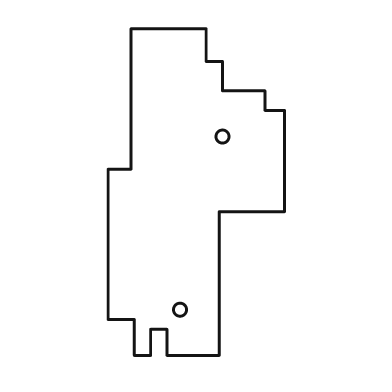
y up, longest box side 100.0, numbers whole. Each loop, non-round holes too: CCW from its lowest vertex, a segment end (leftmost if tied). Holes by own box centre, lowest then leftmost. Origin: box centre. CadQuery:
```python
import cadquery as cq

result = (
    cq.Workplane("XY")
    .moveTo(-19.0, -50.0)
    .lineTo(-14.0, -50.0)
    .lineTo(-14.0, -42.0)
    .lineTo(-9.0, -42.0)
    .lineTo(-9.0, -50.0)
    .lineTo(7.0, -50.0)
    .lineTo(7.0, -6.0)
    .lineTo(27.0, -6.0)
    .lineTo(27.0, 25.0)
    .lineTo(21.0, 25.0)
    .lineTo(21.0, 31.0)
    .lineTo(8.0, 31.0)
    .lineTo(8.0, 40.0)
    .lineTo(3.0, 40.0)
    .lineTo(3.0, 50.0)
    .lineTo(-20.0, 50.0)
    .lineTo(-20.0, 7.0)
    .lineTo(-27.0, 7.0)
    .lineTo(-27.0, -39.0)
    .lineTo(-19.0, -39.0)
    .close()
    .moveTo(-5.0, -36.0)
    .circle(2.0)
    .moveTo(8.0, 17.0)
    .circle(2.0)
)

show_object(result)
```